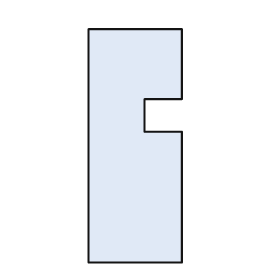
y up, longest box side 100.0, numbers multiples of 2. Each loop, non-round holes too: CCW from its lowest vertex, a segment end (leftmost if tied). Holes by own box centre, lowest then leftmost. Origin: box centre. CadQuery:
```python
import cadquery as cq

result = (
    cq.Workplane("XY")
    .moveTo(-20.0, -50.0)
    .lineTo(20.0, -50.0)
    .lineTo(20.0, 6.0)
    .lineTo(4.0, 6.0)
    .lineTo(4.0, 20.0)
    .lineTo(20.0, 20.0)
    .lineTo(20.0, 50.0)
    .lineTo(-20.0, 50.0)
    .close()
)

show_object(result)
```